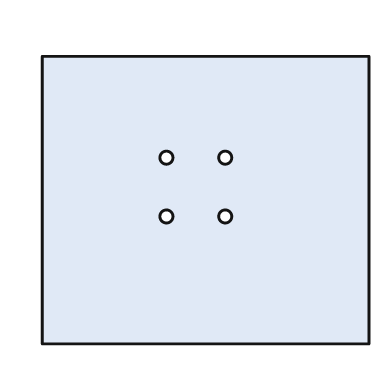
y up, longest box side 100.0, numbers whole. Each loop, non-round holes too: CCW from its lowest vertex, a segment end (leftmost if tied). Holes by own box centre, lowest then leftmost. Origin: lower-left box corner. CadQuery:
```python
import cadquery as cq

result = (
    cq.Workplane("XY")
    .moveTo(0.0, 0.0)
    .lineTo(100.0, 0.0)
    .lineTo(100.0, 88.0)
    .lineTo(0.0, 88.0)
    .close()
    .moveTo(38.0, 39.0)
    .circle(2.0)
    .moveTo(56.0, 39.0)
    .circle(2.0)
    .moveTo(38.0, 57.0)
    .circle(2.0)
    .moveTo(56.0, 57.0)
    .circle(2.0)
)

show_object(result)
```